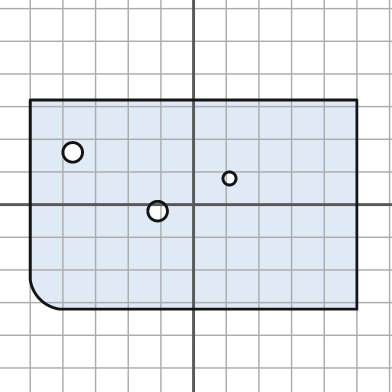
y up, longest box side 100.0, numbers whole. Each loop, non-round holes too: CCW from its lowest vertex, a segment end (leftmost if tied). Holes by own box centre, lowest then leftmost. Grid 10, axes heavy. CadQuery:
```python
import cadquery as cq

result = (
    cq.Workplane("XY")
    .moveTo(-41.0, -32.0)
    .lineTo(50.0, -32.0)
    .lineTo(50.0, 32.0)
    .lineTo(-50.0, 32.0)
    .lineTo(-50.0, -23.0)
    .threePointArc((-47.0, -29.0), (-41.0, -32.0))
    .close()
    .moveTo(-11.0, -2.0)
    .circle(3.0)
    .moveTo(11.0, 8.0)
    .circle(2.0)
    .moveTo(-37.0, 16.0)
    .circle(3.0)
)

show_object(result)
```